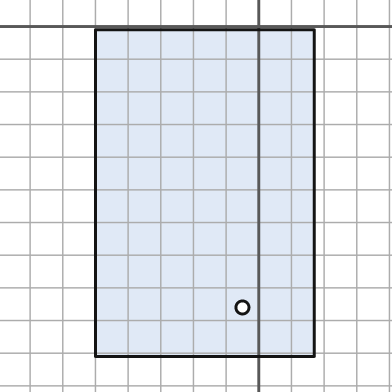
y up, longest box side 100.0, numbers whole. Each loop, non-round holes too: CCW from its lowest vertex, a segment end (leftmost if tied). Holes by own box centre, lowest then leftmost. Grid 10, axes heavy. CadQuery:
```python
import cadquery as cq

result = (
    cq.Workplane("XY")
    .moveTo(-50.0, -101.0)
    .lineTo(17.0, -101.0)
    .lineTo(17.0, -1.0)
    .lineTo(-50.0, -1.0)
    .close()
    .moveTo(-5.0, -86.0)
    .circle(2.0)
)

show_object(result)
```